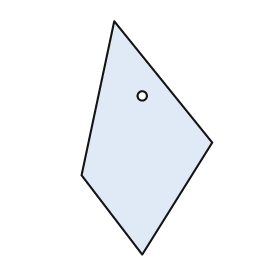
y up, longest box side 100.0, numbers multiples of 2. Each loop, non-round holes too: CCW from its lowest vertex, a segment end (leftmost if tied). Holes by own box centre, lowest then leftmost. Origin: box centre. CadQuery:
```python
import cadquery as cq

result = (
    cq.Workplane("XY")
    .moveTo(-2.0, -50.0)
    .lineTo(28.0, -2.0)
    .lineTo(-14.0, 50.0)
    .lineTo(-28.0, -16.0)
    .close()
    .moveTo(-2.0, 18.0)
    .circle(2.0)
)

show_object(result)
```